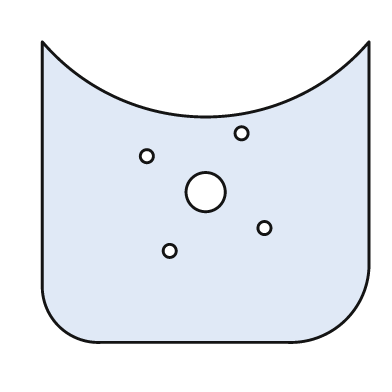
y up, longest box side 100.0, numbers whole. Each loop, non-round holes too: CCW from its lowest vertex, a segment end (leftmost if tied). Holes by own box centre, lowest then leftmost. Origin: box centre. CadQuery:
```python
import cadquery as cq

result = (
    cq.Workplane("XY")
    .moveTo(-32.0, -46.0)
    .lineTo(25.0, -46.0)
    .threePointArc((43.0, -39.0), (50.0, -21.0))
    .lineTo(50.0, 46.0)
    .threePointArc((0.0, 23.0), (-50.0, 46.0))
    .lineTo(-50.0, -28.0)
    .threePointArc((-45.0, -41.0), (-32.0, -46.0))
    .close()
    .moveTo(-11.0, -18.0)
    .circle(2.0)
    .moveTo(18.0, -11.0)
    .circle(2.0)
    .moveTo(0.0, 0.0)
    .circle(6.0)
    .moveTo(-18.0, 11.0)
    .circle(2.0)
    .moveTo(11.0, 18.0)
    .circle(2.0)
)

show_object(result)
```